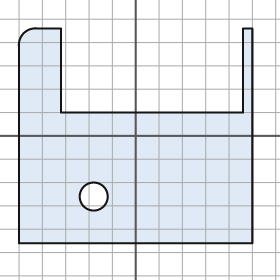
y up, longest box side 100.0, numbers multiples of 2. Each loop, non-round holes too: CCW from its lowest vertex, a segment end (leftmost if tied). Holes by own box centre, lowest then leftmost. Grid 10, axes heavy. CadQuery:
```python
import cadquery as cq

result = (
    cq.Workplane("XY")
    .moveTo(-50.0, -46.0)
    .lineTo(50.0, -46.0)
    .lineTo(50.0, 46.0)
    .lineTo(46.0, 46.0)
    .lineTo(46.0, 10.0)
    .lineTo(-32.0, 10.0)
    .lineTo(-32.0, 46.0)
    .lineTo(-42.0, 46.0)
    .threePointArc((-48.0, 44.0), (-50.0, 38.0))
    .close()
    .moveTo(-18.0, -26.0)
    .circle(6.0)
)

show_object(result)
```